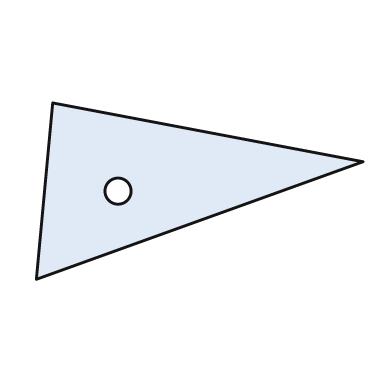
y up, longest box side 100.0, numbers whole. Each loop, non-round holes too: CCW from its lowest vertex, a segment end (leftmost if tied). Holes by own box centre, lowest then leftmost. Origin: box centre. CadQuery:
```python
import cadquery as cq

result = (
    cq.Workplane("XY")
    .moveTo(-50.0, -27.0)
    .lineTo(50.0, 9.0)
    .lineTo(-45.0, 27.0)
    .close()
    .moveTo(-25.0, 0.0)
    .circle(4.0)
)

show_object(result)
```